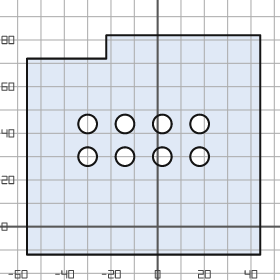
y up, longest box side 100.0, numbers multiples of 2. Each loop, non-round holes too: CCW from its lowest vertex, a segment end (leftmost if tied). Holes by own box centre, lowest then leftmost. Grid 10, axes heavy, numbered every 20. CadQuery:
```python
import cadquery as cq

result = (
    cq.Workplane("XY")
    .moveTo(-56.0, -12.0)
    .lineTo(44.0, -12.0)
    .lineTo(44.0, 82.0)
    .lineTo(-22.0, 82.0)
    .lineTo(-22.0, 72.0)
    .lineTo(-56.0, 72.0)
    .close()
    .moveTo(-30.0, 30.0)
    .circle(4.0)
    .moveTo(-14.0, 30.0)
    .circle(4.0)
    .moveTo(2.0, 30.0)
    .circle(4.0)
    .moveTo(18.0, 30.0)
    .circle(4.0)
    .moveTo(-30.0, 44.0)
    .circle(4.0)
    .moveTo(-14.0, 44.0)
    .circle(4.0)
    .moveTo(2.0, 44.0)
    .circle(4.0)
    .moveTo(18.0, 44.0)
    .circle(4.0)
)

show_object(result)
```